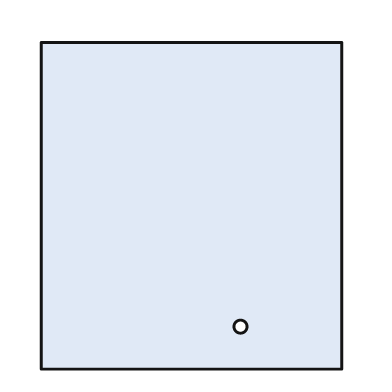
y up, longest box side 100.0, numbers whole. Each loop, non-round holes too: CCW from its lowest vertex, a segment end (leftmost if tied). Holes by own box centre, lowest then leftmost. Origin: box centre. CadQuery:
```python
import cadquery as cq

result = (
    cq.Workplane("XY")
    .moveTo(-46.0, -50.0)
    .lineTo(46.0, -50.0)
    .lineTo(46.0, 50.0)
    .lineTo(-46.0, 50.0)
    .close()
    .moveTo(15.0, -37.0)
    .circle(2.0)
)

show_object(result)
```